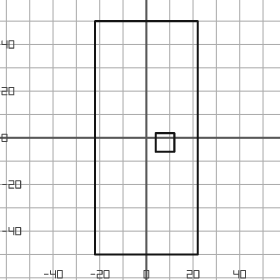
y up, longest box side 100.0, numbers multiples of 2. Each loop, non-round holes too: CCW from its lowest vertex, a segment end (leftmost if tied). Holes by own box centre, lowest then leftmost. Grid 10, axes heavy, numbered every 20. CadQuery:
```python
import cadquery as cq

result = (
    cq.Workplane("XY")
    .moveTo(-22.0, -50.0)
    .lineTo(22.0, -50.0)
    .lineTo(22.0, 50.0)
    .lineTo(-22.0, 50.0)
    .close()
    .moveTo(4.0, -6.0)
    .lineTo(12.0, -6.0)
    .lineTo(12.0, 2.0)
    .lineTo(4.0, 2.0)
    .close()
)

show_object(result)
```